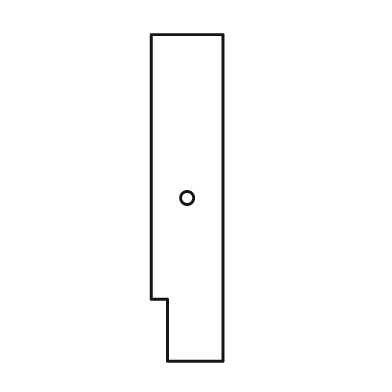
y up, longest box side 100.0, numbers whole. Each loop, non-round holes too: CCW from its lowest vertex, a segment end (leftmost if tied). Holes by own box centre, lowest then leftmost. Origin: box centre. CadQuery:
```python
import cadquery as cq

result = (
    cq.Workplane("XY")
    .moveTo(-6.0, -50.0)
    .lineTo(11.0, -50.0)
    .lineTo(11.0, 50.0)
    .lineTo(-11.0, 50.0)
    .lineTo(-11.0, -31.0)
    .lineTo(-6.0, -31.0)
    .close()
    .moveTo(0.0, 0.0)
    .circle(2.0)
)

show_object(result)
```